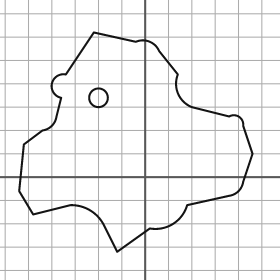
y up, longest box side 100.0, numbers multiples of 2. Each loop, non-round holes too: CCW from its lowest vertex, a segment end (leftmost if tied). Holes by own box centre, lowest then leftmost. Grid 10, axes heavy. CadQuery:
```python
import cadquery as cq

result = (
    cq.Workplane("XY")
    .moveTo(-12.0, -32.0)
    .lineTo(2.0, -22.0)
    .threePointArc((12.0, -20.0), (18.0, -12.0))
    .lineTo(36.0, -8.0)
    .threePointArc((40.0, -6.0), (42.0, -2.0))
    .lineTo(46.0, 10.0)
    .lineTo(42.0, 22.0)
    .threePointArc((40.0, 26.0), (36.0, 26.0))
    .lineTo(20.0, 30.0)
    .threePointArc((14.0, 36.0), (14.0, 44.0))
    .lineTo(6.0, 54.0)
    .threePointArc((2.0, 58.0), (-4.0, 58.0))
    .lineTo(-22.0, 62.0)
    .lineTo(-34.0, 44.0)
    .threePointArc((-40.0, 40.0), (-36.0, 34.0))
    .lineTo(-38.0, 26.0)
    .threePointArc((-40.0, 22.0), (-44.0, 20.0))
    .lineTo(-52.0, 14.0)
    .lineTo(-54.0, -6.0)
    .lineTo(-48.0, -16.0)
    .lineTo(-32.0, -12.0)
    .threePointArc((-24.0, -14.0), (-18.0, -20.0))
    .close()
    .moveTo(-20.0, 34.0)
    .circle(4.0)
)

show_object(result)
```